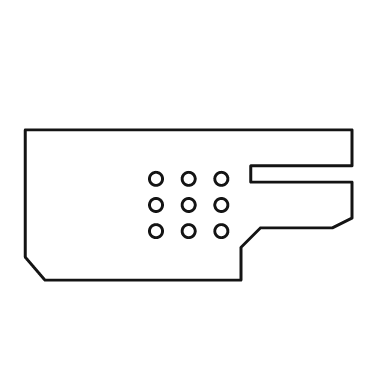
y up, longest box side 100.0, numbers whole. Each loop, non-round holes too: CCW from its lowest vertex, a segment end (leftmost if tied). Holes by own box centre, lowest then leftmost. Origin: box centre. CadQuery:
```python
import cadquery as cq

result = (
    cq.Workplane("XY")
    .moveTo(-44.0, -23.0)
    .lineTo(16.0, -23.0)
    .lineTo(16.0, -13.0)
    .lineTo(22.0, -7.0)
    .lineTo(44.0, -7.0)
    .lineTo(50.0, -4.0)
    .lineTo(50.0, 7.0)
    .lineTo(19.0, 7.0)
    .lineTo(19.0, 12.0)
    .lineTo(50.0, 12.0)
    .lineTo(50.0, 23.0)
    .lineTo(-50.0, 23.0)
    .lineTo(-50.0, -16.0)
    .close()
    .moveTo(-10.0, -8.0)
    .circle(2.0)
    .moveTo(0.0, -8.0)
    .circle(2.0)
    .moveTo(10.0, -8.0)
    .circle(2.0)
    .moveTo(-10.0, 0.0)
    .circle(2.0)
    .moveTo(0.0, 0.0)
    .circle(2.0)
    .moveTo(10.0, 0.0)
    .circle(2.0)
    .moveTo(-10.0, 8.0)
    .circle(2.0)
    .moveTo(0.0, 8.0)
    .circle(2.0)
    .moveTo(10.0, 8.0)
    .circle(2.0)
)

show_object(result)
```